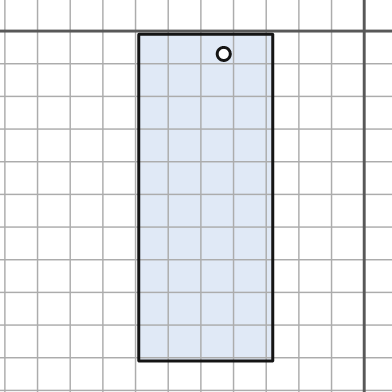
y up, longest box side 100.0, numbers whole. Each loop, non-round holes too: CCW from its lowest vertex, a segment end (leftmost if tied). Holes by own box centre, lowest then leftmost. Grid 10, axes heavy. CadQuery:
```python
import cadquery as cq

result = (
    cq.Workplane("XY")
    .moveTo(-69.0, -101.0)
    .lineTo(-28.0, -101.0)
    .lineTo(-28.0, -1.0)
    .lineTo(-69.0, -1.0)
    .close()
    .moveTo(-43.0, -7.0)
    .circle(2.0)
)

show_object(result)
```